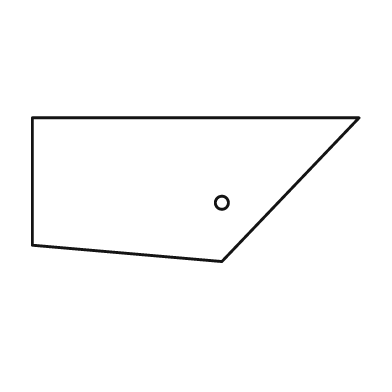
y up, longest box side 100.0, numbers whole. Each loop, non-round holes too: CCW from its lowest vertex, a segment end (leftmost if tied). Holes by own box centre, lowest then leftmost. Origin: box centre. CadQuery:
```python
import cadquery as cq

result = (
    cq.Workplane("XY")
    .moveTo(8.0, -22.0)
    .lineTo(50.0, 22.0)
    .lineTo(-50.0, 22.0)
    .lineTo(-50.0, -17.0)
    .close()
    .moveTo(8.0, -4.0)
    .circle(2.0)
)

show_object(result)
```